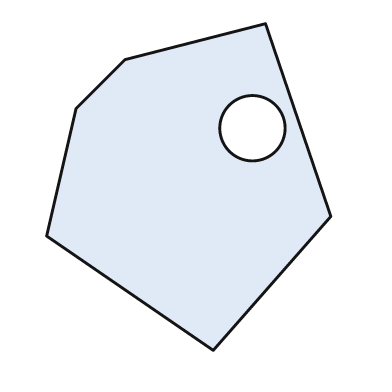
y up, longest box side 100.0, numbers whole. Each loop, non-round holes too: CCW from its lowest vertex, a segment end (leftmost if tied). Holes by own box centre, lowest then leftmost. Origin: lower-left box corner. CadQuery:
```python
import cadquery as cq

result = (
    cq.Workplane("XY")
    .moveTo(51.0, 0.0)
    .lineTo(87.0, 41.0)
    .lineTo(67.0, 100.0)
    .lineTo(24.0, 89.0)
    .lineTo(9.0, 74.0)
    .lineTo(0.0, 35.0)
    .close()
    .moveTo(63.0, 68.0)
    .circle(10.0)
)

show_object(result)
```